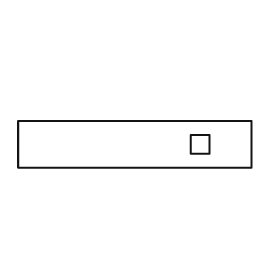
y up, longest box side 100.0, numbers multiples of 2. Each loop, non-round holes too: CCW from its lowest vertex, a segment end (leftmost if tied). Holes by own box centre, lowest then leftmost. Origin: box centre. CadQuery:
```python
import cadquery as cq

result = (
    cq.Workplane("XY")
    .moveTo(-50.0, -10.0)
    .lineTo(50.0, -10.0)
    .lineTo(50.0, 10.0)
    .lineTo(-50.0, 10.0)
    .close()
    .moveTo(24.0, -4.0)
    .lineTo(32.0, -4.0)
    .lineTo(32.0, 4.0)
    .lineTo(24.0, 4.0)
    .close()
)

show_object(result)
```